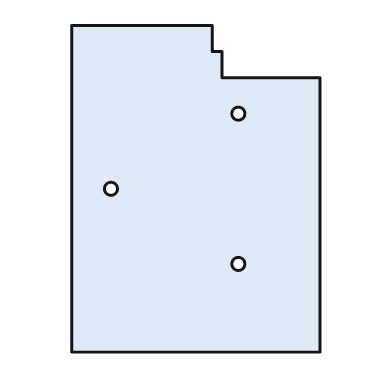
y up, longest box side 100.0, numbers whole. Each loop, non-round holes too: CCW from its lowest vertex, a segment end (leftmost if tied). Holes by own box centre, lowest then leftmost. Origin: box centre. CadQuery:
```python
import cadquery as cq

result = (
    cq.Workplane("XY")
    .moveTo(-38.0, -50.0)
    .lineTo(38.0, -50.0)
    .lineTo(38.0, 34.0)
    .lineTo(8.0, 34.0)
    .lineTo(8.0, 42.0)
    .lineTo(5.0, 42.0)
    .lineTo(5.0, 50.0)
    .lineTo(-38.0, 50.0)
    .close()
    .moveTo(13.0, -23.0)
    .circle(2.0)
    .moveTo(-26.0, 0.0)
    .circle(2.0)
    .moveTo(13.0, 23.0)
    .circle(2.0)
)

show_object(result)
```